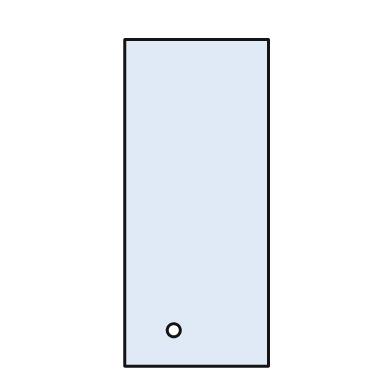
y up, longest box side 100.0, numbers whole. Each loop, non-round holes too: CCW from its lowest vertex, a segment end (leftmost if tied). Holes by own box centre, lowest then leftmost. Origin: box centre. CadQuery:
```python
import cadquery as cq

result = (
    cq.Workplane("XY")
    .moveTo(-22.0, -50.0)
    .lineTo(22.0, -50.0)
    .lineTo(22.0, 50.0)
    .lineTo(-22.0, 50.0)
    .close()
    .moveTo(-7.0, -39.0)
    .circle(2.0)
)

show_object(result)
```